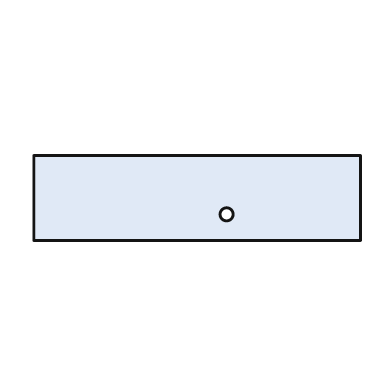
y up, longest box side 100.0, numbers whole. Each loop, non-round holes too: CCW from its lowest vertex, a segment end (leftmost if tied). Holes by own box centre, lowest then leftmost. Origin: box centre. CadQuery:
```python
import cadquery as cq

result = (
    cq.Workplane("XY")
    .moveTo(-50.0, -13.0)
    .lineTo(50.0, -13.0)
    .lineTo(50.0, 13.0)
    .lineTo(-50.0, 13.0)
    .close()
    .moveTo(9.0, -5.0)
    .circle(2.0)
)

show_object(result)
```